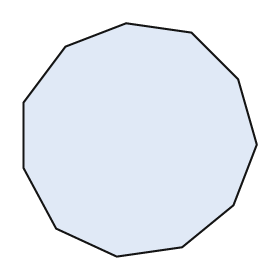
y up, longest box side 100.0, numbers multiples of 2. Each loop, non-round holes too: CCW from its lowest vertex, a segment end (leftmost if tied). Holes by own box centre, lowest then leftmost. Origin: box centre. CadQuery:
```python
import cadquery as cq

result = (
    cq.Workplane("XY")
    .moveTo(-10.0, -50.0)
    .lineTo(18.0, -46.0)
    .lineTo(40.0, -28.0)
    .lineTo(50.0, -2.0)
    .lineTo(42.0, 26.0)
    .lineTo(22.0, 46.0)
    .lineTo(-6.0, 50.0)
    .lineTo(-32.0, 40.0)
    .lineTo(-50.0, 16.0)
    .lineTo(-50.0, -12.0)
    .lineTo(-36.0, -38.0)
    .close()
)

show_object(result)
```